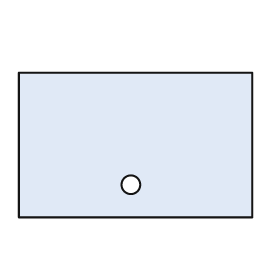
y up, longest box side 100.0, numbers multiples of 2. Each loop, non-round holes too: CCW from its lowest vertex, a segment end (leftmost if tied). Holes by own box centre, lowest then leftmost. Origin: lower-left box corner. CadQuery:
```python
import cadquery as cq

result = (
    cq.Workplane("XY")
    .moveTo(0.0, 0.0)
    .lineTo(100.0, 0.0)
    .lineTo(100.0, 62.0)
    .lineTo(0.0, 62.0)
    .close()
    .moveTo(48.0, 14.0)
    .circle(4.0)
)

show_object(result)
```